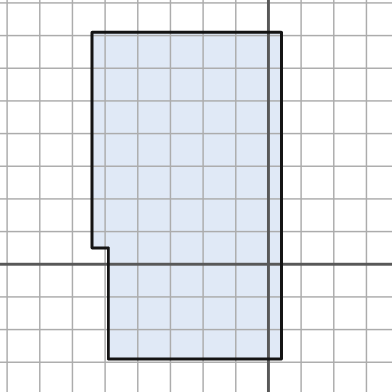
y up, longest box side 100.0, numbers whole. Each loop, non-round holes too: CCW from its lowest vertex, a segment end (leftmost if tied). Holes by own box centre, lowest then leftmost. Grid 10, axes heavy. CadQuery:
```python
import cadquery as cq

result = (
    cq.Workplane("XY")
    .moveTo(-49.0, -29.0)
    .lineTo(4.0, -29.0)
    .lineTo(4.0, 71.0)
    .lineTo(-54.0, 71.0)
    .lineTo(-54.0, 5.0)
    .lineTo(-49.0, 5.0)
    .close()
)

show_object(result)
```